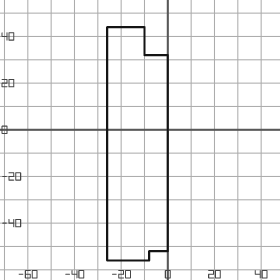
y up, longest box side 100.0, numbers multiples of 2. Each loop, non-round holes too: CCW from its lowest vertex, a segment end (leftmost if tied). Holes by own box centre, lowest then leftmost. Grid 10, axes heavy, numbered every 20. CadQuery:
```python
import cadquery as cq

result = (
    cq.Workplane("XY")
    .moveTo(-26.0, -56.0)
    .lineTo(-8.0, -56.0)
    .lineTo(-8.0, -52.0)
    .lineTo(0.0, -52.0)
    .lineTo(0.0, 32.0)
    .lineTo(-10.0, 32.0)
    .lineTo(-10.0, 44.0)
    .lineTo(-26.0, 44.0)
    .close()
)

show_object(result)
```